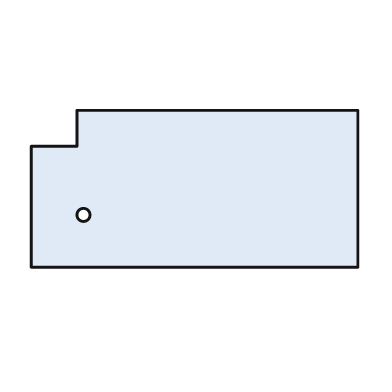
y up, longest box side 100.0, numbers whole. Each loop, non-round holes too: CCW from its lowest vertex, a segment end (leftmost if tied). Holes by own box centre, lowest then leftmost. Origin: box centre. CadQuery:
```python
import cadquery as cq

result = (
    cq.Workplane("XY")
    .moveTo(-50.0, -24.0)
    .lineTo(50.0, -24.0)
    .lineTo(50.0, 24.0)
    .lineTo(-36.0, 24.0)
    .lineTo(-36.0, 13.0)
    .lineTo(-50.0, 13.0)
    .close()
    .moveTo(-34.0, -8.0)
    .circle(2.0)
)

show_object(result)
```